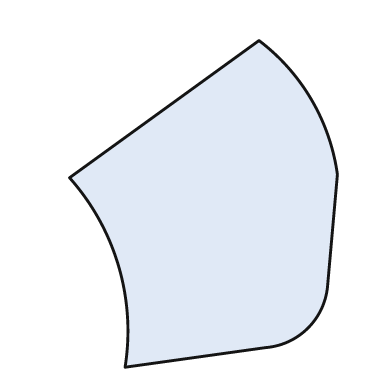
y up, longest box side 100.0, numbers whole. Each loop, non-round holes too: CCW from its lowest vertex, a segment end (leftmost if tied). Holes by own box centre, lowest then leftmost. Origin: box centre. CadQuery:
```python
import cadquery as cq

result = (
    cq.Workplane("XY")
    .moveTo(-24.0, -50.0)
    .lineTo(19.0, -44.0)
    .threePointArc((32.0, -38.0), (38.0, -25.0))
    .lineTo(41.0, 9.0)
    .threePointArc((33.0, 32.0), (17.0, 50.0))
    .lineTo(-41.0, 8.0)
    .threePointArc((-26.0, -19.0), (-24.0, -50.0))
    .close()
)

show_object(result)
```